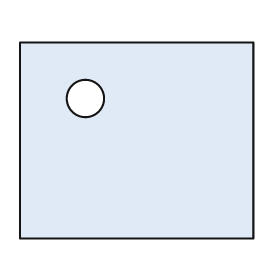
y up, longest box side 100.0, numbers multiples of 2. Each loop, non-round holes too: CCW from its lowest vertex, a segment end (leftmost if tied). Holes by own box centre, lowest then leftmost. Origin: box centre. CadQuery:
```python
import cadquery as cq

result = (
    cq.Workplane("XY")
    .moveTo(-50.0, -42.0)
    .lineTo(50.0, -42.0)
    .lineTo(50.0, 42.0)
    .lineTo(-50.0, 42.0)
    .close()
    .moveTo(-22.0, 18.0)
    .circle(8.0)
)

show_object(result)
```